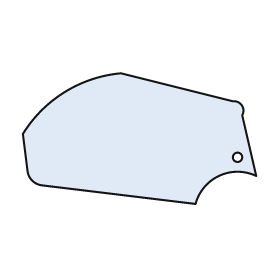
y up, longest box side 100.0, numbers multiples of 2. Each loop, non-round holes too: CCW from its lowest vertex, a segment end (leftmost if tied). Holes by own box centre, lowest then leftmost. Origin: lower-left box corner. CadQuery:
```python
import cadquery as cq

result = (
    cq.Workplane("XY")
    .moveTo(74.0, 0.0)
    .threePointArc((84.0, 12.0), (100.0, 12.0))
    .lineTo(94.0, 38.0)
    .threePointArc((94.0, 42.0), (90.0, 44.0))
    .lineTo(42.0, 56.0)
    .threePointArc((18.0, 48.0), (0.0, 30.0))
    .lineTo(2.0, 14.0)
    .threePointArc((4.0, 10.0), (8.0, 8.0))
    .close()
    .moveTo(92.0, 20.0)
    .circle(2.0)
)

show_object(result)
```